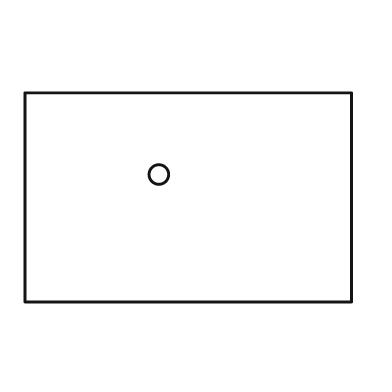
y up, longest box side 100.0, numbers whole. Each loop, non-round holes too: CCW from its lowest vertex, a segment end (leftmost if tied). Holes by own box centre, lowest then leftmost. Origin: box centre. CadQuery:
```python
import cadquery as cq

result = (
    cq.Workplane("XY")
    .moveTo(-50.0, -32.0)
    .lineTo(50.0, -32.0)
    .lineTo(50.0, 32.0)
    .lineTo(-50.0, 32.0)
    .close()
    .moveTo(-9.0, 7.0)
    .circle(3.0)
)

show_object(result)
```